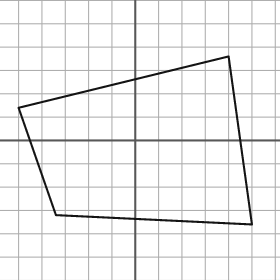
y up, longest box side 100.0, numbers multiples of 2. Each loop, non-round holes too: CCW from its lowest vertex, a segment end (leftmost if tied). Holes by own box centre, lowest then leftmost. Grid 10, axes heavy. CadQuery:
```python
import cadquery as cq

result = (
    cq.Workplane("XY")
    .moveTo(50.0, -36.0)
    .lineTo(40.0, 36.0)
    .lineTo(-50.0, 14.0)
    .lineTo(-34.0, -32.0)
    .close()
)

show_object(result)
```